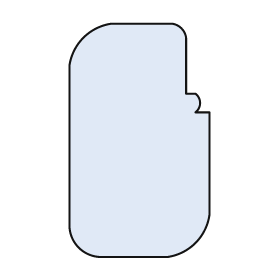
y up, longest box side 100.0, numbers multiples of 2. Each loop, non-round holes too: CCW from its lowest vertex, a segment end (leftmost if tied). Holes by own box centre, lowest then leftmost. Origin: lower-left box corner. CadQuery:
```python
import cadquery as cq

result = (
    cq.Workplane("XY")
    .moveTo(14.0, 0.0)
    .lineTo(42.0, 0.0)
    .threePointArc((54.0, 6.0), (60.0, 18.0))
    .lineTo(60.0, 62.0)
    .lineTo(54.0, 62.0)
    .threePointArc((56.0, 66.0), (54.0, 70.0))
    .lineTo(50.0, 70.0)
    .lineTo(50.0, 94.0)
    .threePointArc((48.0, 98.0), (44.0, 100.0))
    .lineTo(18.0, 100.0)
    .threePointArc((6.0, 94.0), (0.0, 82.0))
    .lineTo(0.0, 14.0)
    .threePointArc((4.0, 4.0), (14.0, 0.0))
    .close()
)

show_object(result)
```